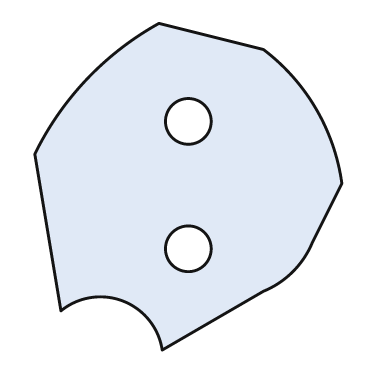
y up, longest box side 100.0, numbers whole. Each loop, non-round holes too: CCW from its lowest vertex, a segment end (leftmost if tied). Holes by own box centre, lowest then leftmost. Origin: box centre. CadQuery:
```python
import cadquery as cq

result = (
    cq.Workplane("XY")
    .moveTo(-8.0, -50.0)
    .lineTo(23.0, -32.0)
    .threePointArc((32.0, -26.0), (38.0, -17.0))
    .lineTo(47.0, 1.0)
    .threePointArc((39.0, 24.0), (23.0, 42.0))
    .lineTo(-9.0, 50.0)
    .threePointArc((-31.0, 33.0), (-47.0, 10.0))
    .lineTo(-39.0, -38.0)
    .threePointArc((-20.0, -35.0), (-8.0, -50.0))
    .close()
    .moveTo(0.0, -19.0)
    .circle(7.0)
    .moveTo(0.0, 20.0)
    .circle(7.0)
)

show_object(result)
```